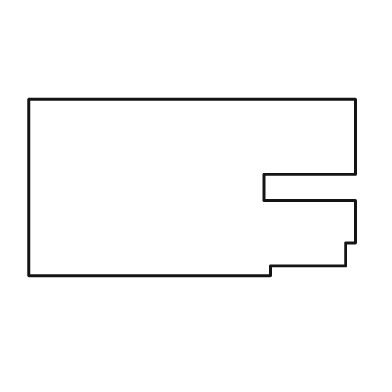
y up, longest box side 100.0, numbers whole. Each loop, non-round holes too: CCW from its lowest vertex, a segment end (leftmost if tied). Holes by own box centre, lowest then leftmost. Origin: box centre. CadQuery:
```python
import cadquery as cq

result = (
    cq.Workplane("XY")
    .moveTo(-50.0, -27.0)
    .lineTo(24.0, -27.0)
    .lineTo(24.0, -24.0)
    .lineTo(47.0, -24.0)
    .lineTo(47.0, -17.0)
    .lineTo(50.0, -17.0)
    .lineTo(50.0, -4.0)
    .lineTo(22.0, -4.0)
    .lineTo(22.0, 4.0)
    .lineTo(50.0, 4.0)
    .lineTo(50.0, 27.0)
    .lineTo(-50.0, 27.0)
    .close()
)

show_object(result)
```